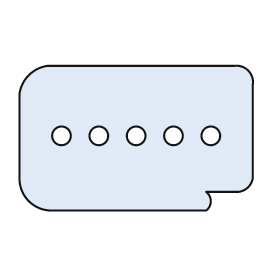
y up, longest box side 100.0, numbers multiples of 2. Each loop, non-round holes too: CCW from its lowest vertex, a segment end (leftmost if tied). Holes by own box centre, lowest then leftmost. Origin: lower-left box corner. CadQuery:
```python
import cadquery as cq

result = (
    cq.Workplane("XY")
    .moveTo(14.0, 0.0)
    .lineTo(80.0, 0.0)
    .threePointArc((82.0, 4.0), (80.0, 8.0))
    .lineTo(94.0, 8.0)
    .threePointArc((98.0, 10.0), (100.0, 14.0))
    .lineTo(100.0, 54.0)
    .threePointArc((98.0, 60.0), (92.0, 62.0))
    .lineTo(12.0, 62.0)
    .threePointArc((4.0, 58.0), (0.0, 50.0))
    .lineTo(0.0, 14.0)
    .threePointArc((4.0, 4.0), (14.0, 0.0))
    .close()
    .moveTo(18.0, 32.0)
    .circle(4.0)
    .moveTo(34.0, 32.0)
    .circle(4.0)
    .moveTo(50.0, 32.0)
    .circle(4.0)
    .moveTo(66.0, 32.0)
    .circle(4.0)
    .moveTo(82.0, 32.0)
    .circle(4.0)
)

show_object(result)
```